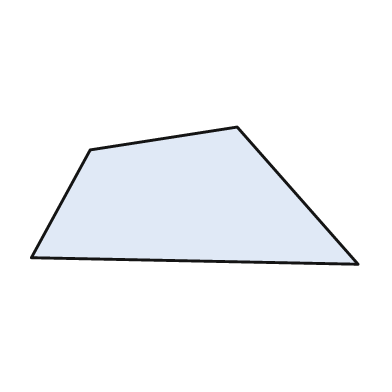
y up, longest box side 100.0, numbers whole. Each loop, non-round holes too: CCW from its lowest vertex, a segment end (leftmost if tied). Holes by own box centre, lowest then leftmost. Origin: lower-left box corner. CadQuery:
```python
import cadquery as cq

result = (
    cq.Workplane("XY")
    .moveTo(100.0, 0.0)
    .lineTo(63.0, 42.0)
    .lineTo(18.0, 35.0)
    .lineTo(0.0, 2.0)
    .close()
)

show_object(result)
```